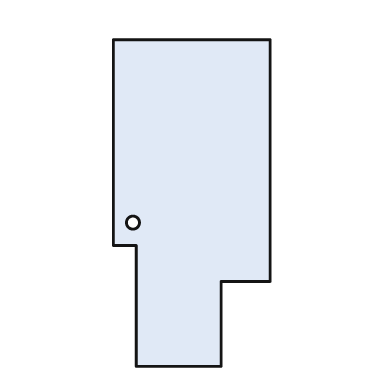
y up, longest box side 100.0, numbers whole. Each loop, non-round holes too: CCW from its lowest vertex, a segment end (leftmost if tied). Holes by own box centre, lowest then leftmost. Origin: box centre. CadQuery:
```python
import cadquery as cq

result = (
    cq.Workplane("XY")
    .moveTo(-17.0, -50.0)
    .lineTo(9.0, -50.0)
    .lineTo(9.0, -24.0)
    .lineTo(24.0, -24.0)
    .lineTo(24.0, 50.0)
    .lineTo(-24.0, 50.0)
    .lineTo(-24.0, -13.0)
    .lineTo(-17.0, -13.0)
    .close()
    .moveTo(-18.0, -6.0)
    .circle(2.0)
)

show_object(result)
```